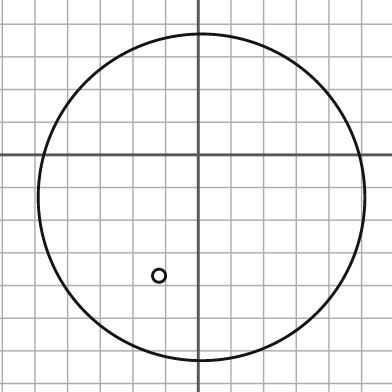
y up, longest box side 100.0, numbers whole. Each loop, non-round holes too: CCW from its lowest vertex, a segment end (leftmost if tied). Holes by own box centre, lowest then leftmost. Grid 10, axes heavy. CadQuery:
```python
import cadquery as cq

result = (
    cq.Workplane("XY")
    .moveTo(1.0, -13.0)
    .circle(50.0)
    .moveTo(-12.0, -37.0)
    .circle(2.0)
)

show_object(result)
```